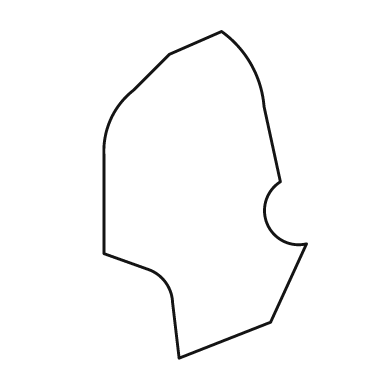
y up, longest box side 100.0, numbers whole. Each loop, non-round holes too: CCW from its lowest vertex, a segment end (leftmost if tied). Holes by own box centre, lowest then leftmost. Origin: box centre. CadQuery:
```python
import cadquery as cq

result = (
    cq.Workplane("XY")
    .moveTo(-8.0, -50.0)
    .lineTo(20.0, -39.0)
    .lineTo(31.0, -15.0)
    .threePointArc((19.0, -9.0), (23.0, 4.0))
    .lineTo(18.0, 27.0)
    .threePointArc((14.0, 40.0), (5.0, 50.0))
    .lineTo(-11.0, 43.0)
    .lineTo(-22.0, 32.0)
    .threePointArc((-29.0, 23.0), (-31.0, 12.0))
    .lineTo(-31.0, -18.0)
    .lineTo(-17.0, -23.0)
    .threePointArc((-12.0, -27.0), (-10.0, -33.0))
    .close()
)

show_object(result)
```